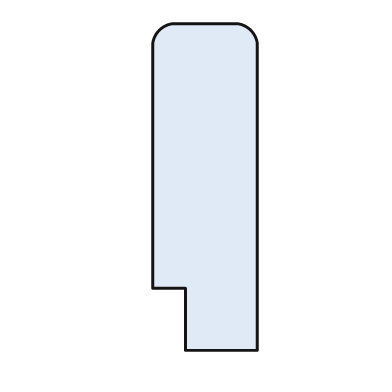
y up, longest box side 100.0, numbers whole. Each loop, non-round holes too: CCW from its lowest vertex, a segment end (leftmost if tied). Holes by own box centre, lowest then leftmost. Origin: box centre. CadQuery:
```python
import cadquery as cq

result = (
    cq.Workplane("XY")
    .moveTo(-6.0, -50.0)
    .lineTo(16.0, -50.0)
    .lineTo(16.0, 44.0)
    .threePointArc((14.0, 48.0), (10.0, 50.0))
    .lineTo(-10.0, 50.0)
    .threePointArc((-14.0, 48.0), (-16.0, 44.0))
    .lineTo(-16.0, -31.0)
    .lineTo(-6.0, -31.0)
    .close()
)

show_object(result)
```